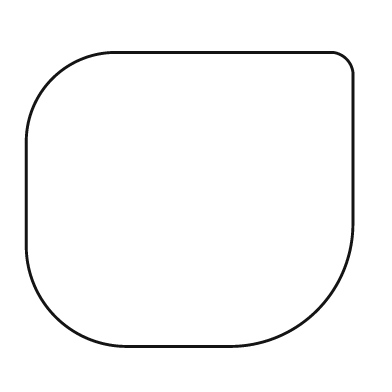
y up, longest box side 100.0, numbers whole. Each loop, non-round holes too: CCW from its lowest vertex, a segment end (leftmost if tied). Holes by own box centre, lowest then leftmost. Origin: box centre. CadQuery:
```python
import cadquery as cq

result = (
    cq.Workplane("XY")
    .moveTo(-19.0, -45.0)
    .lineTo(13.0, -45.0)
    .threePointArc((39.0, -34.0), (50.0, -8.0))
    .lineTo(50.0, 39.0)
    .threePointArc((48.0, 43.0), (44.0, 45.0))
    .lineTo(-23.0, 45.0)
    .threePointArc((-42.0, 37.0), (-50.0, 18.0))
    .lineTo(-50.0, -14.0)
    .threePointArc((-41.0, -36.0), (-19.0, -45.0))
    .close()
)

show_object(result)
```